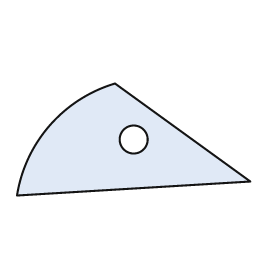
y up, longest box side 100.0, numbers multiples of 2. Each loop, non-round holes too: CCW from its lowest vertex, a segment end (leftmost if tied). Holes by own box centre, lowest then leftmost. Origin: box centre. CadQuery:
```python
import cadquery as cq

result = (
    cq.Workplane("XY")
    .moveTo(-50.0, -24.0)
    .lineTo(50.0, -18.0)
    .lineTo(-8.0, 24.0)
    .threePointArc((-36.0, 6.0), (-50.0, -24.0))
    .close()
    .moveTo(0.0, 0.0)
    .circle(6.0)
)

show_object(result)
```